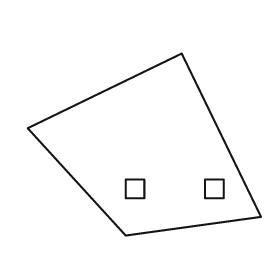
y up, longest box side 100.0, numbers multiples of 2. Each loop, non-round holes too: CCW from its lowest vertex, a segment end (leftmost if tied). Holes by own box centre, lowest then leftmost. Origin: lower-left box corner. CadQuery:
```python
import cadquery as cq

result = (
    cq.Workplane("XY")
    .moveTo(42.0, 0.0)
    .lineTo(100.0, 8.0)
    .lineTo(66.0, 78.0)
    .lineTo(0.0, 46.0)
    .close()
    .moveTo(42.0, 16.0)
    .lineTo(50.0, 16.0)
    .lineTo(50.0, 24.0)
    .lineTo(42.0, 24.0)
    .close()
    .moveTo(76.0, 16.0)
    .lineTo(84.0, 16.0)
    .lineTo(84.0, 24.0)
    .lineTo(76.0, 24.0)
    .close()
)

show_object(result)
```